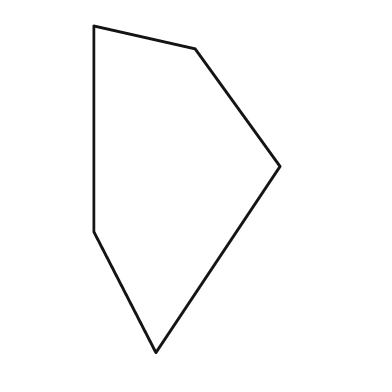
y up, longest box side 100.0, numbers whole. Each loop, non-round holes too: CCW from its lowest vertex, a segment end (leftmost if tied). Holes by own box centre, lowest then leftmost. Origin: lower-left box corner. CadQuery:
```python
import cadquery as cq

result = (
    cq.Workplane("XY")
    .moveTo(19.0, 0.0)
    .lineTo(57.0, 57.0)
    .lineTo(31.0, 93.0)
    .lineTo(0.0, 100.0)
    .lineTo(0.0, 37.0)
    .close()
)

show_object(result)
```